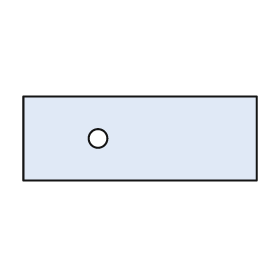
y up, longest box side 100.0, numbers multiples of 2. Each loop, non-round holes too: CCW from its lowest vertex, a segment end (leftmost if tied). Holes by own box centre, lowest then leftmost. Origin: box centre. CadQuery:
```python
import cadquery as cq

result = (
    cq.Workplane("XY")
    .moveTo(-50.0, -18.0)
    .lineTo(50.0, -18.0)
    .lineTo(50.0, 18.0)
    .lineTo(-50.0, 18.0)
    .close()
    .moveTo(-18.0, 0.0)
    .circle(4.0)
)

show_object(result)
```